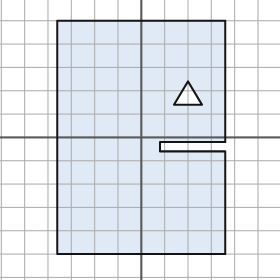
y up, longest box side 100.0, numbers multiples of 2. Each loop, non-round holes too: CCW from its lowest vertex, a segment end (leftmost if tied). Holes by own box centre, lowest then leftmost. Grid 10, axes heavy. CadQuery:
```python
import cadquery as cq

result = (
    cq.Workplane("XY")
    .moveTo(-36.0, -50.0)
    .lineTo(36.0, -50.0)
    .lineTo(36.0, -6.0)
    .lineTo(8.0, -6.0)
    .lineTo(8.0, -2.0)
    .lineTo(36.0, -2.0)
    .lineTo(36.0, 50.0)
    .lineTo(-36.0, 50.0)
    .close()
    .moveTo(14.0, 14.0)
    .lineTo(26.0, 14.0)
    .lineTo(20.0, 24.0)
    .close()
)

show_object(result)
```